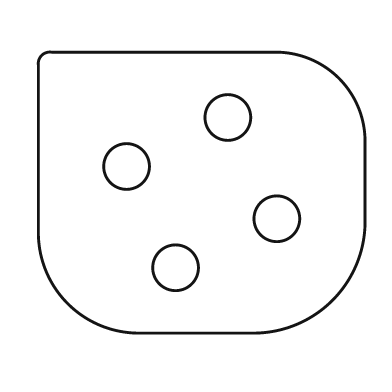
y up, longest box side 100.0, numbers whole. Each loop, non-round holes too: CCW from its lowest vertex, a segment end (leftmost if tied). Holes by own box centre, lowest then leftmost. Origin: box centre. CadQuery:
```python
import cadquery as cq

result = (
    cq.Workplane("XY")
    .moveTo(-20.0, -43.0)
    .lineTo(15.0, -43.0)
    .threePointArc((40.0, -33.0), (50.0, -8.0))
    .lineTo(50.0, 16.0)
    .threePointArc((42.0, 35.0), (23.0, 43.0))
    .lineTo(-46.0, 43.0)
    .threePointArc((-49.0, 42.0), (-50.0, 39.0))
    .lineTo(-50.0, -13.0)
    .threePointArc((-41.0, -34.0), (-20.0, -43.0))
    .close()
    .moveTo(-8.0, -23.0)
    .circle(7.0)
    .moveTo(23.0, -8.0)
    .circle(7.0)
    .moveTo(-23.0, 8.0)
    .circle(7.0)
    .moveTo(8.0, 23.0)
    .circle(7.0)
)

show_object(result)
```